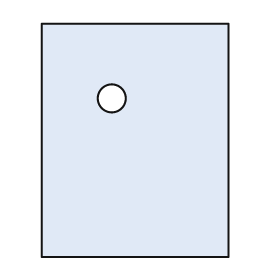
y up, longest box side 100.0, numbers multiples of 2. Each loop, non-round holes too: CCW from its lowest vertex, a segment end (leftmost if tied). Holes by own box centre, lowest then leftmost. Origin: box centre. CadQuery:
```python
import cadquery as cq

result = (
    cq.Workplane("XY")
    .moveTo(-40.0, -50.0)
    .lineTo(40.0, -50.0)
    .lineTo(40.0, 50.0)
    .lineTo(-40.0, 50.0)
    .close()
    .moveTo(-10.0, 18.0)
    .circle(6.0)
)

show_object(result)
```